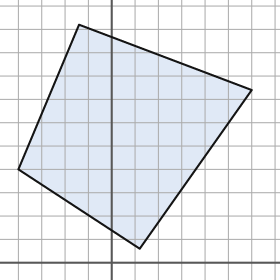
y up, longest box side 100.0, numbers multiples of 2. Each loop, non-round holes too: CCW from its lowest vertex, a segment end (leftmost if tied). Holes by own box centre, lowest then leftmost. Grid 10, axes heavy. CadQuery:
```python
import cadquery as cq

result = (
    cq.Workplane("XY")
    .moveTo(12.0, 6.0)
    .lineTo(60.0, 74.0)
    .lineTo(-14.0, 102.0)
    .lineTo(-40.0, 40.0)
    .close()
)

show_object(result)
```